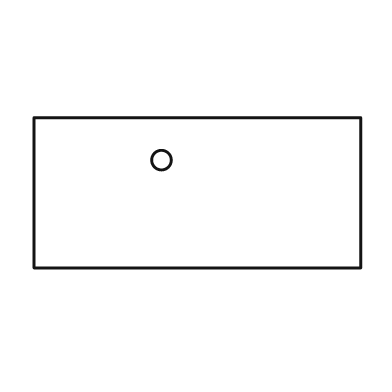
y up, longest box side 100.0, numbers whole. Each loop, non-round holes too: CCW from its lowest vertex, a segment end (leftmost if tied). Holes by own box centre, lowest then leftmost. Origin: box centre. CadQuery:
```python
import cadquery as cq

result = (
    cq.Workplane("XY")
    .moveTo(-50.0, -23.0)
    .lineTo(50.0, -23.0)
    .lineTo(50.0, 23.0)
    .lineTo(-50.0, 23.0)
    .close()
    .moveTo(-11.0, 10.0)
    .circle(3.0)
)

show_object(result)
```